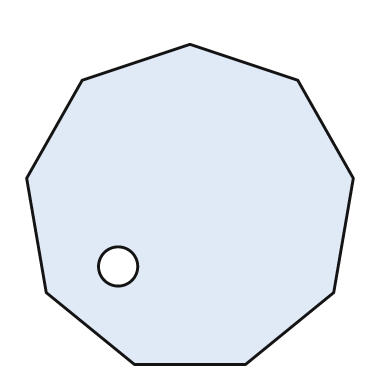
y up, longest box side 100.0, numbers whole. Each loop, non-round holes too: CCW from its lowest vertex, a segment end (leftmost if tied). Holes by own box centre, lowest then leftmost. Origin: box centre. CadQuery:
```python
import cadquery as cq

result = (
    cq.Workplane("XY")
    .moveTo(-17.0, -49.0)
    .lineTo(17.0, -49.0)
    .lineTo(44.0, -27.0)
    .lineTo(50.0, 8.0)
    .lineTo(33.0, 38.0)
    .lineTo(0.0, 49.0)
    .lineTo(-33.0, 38.0)
    .lineTo(-50.0, 8.0)
    .lineTo(-44.0, -27.0)
    .close()
    .moveTo(-22.0, -19.0)
    .circle(6.0)
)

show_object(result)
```